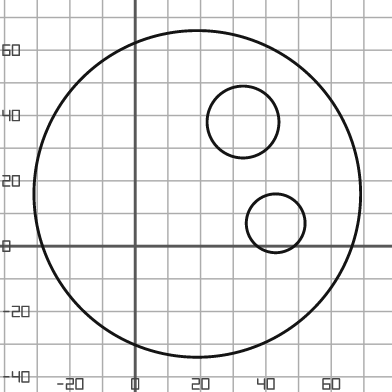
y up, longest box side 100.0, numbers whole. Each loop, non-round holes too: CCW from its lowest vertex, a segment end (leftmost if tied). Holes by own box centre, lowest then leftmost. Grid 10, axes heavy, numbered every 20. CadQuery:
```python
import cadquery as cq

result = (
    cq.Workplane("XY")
    .moveTo(19.0, 16.0)
    .circle(50.0)
    .moveTo(43.0, 7.0)
    .circle(9.0)
    .moveTo(33.0, 38.0)
    .circle(11.0)
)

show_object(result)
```